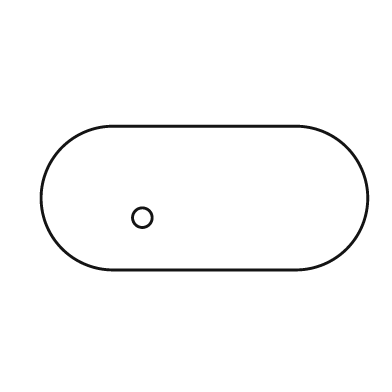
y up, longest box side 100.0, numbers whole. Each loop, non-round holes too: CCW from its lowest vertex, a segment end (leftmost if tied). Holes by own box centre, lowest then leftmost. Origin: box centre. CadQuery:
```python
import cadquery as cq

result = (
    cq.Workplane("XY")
    .moveTo(-28.0, -22.0)
    .lineTo(28.0, -22.0)
    .threePointArc((50.0, 0.0), (28.0, 22.0))
    .lineTo(-28.0, 22.0)
    .threePointArc((-50.0, 0.0), (-28.0, -22.0))
    .close()
    .moveTo(-19.0, -6.0)
    .circle(3.0)
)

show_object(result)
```